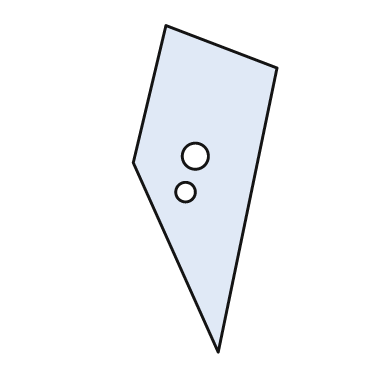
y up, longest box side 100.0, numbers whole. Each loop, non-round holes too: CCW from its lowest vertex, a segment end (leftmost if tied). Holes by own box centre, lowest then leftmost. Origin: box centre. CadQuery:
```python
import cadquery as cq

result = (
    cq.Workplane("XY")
    .moveTo(4.0, -50.0)
    .lineTo(22.0, 37.0)
    .lineTo(-12.0, 50.0)
    .lineTo(-22.0, 8.0)
    .close()
    .moveTo(-6.0, -1.0)
    .circle(3.0)
    .moveTo(-3.0, 10.0)
    .circle(4.0)
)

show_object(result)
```